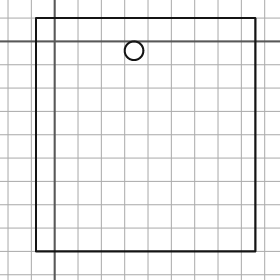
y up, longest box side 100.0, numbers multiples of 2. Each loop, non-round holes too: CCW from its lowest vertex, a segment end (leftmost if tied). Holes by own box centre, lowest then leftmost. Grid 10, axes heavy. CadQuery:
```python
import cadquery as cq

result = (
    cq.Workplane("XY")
    .moveTo(-8.0, -90.0)
    .lineTo(86.0, -90.0)
    .lineTo(86.0, 10.0)
    .lineTo(-8.0, 10.0)
    .close()
    .moveTo(34.0, -4.0)
    .circle(4.0)
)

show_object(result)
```